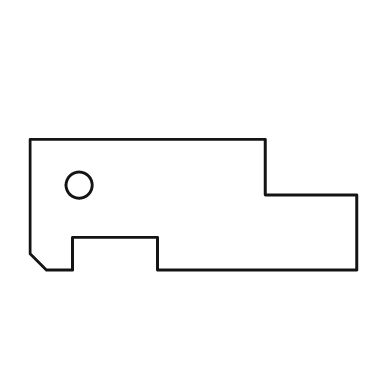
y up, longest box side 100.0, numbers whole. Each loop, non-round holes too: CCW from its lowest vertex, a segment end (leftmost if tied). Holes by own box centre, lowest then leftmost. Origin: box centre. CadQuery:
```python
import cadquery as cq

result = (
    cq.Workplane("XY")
    .moveTo(-45.0, -20.0)
    .lineTo(-37.0, -20.0)
    .lineTo(-37.0, -10.0)
    .lineTo(-11.0, -10.0)
    .lineTo(-11.0, -20.0)
    .lineTo(50.0, -20.0)
    .lineTo(50.0, 3.0)
    .lineTo(22.0, 3.0)
    .lineTo(22.0, 20.0)
    .lineTo(-50.0, 20.0)
    .lineTo(-50.0, -15.0)
    .close()
    .moveTo(-35.0, 6.0)
    .circle(4.0)
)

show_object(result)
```